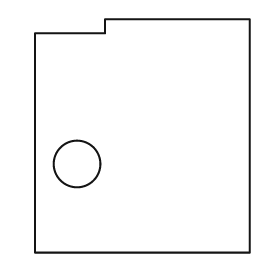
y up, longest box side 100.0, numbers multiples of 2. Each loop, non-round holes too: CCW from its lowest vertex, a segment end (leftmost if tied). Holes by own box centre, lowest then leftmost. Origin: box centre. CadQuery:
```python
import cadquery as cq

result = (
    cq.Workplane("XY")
    .moveTo(-46.0, -50.0)
    .lineTo(46.0, -50.0)
    .lineTo(46.0, 50.0)
    .lineTo(-16.0, 50.0)
    .lineTo(-16.0, 44.0)
    .lineTo(-46.0, 44.0)
    .close()
    .moveTo(-28.0, -12.0)
    .circle(10.0)
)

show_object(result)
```